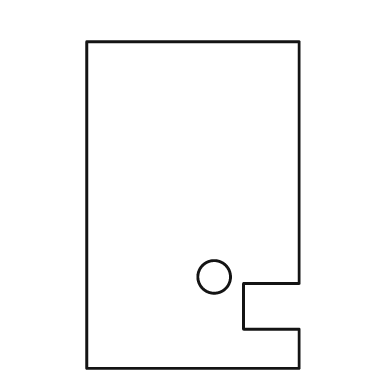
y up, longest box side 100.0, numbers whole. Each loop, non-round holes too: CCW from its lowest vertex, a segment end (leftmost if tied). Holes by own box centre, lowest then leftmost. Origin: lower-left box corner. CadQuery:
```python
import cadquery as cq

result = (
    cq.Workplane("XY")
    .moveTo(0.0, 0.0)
    .lineTo(65.0, 0.0)
    .lineTo(65.0, 12.0)
    .lineTo(48.0, 12.0)
    .lineTo(48.0, 26.0)
    .lineTo(65.0, 26.0)
    .lineTo(65.0, 100.0)
    .lineTo(0.0, 100.0)
    .close()
    .moveTo(39.0, 28.0)
    .circle(5.0)
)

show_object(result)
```